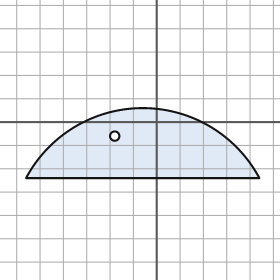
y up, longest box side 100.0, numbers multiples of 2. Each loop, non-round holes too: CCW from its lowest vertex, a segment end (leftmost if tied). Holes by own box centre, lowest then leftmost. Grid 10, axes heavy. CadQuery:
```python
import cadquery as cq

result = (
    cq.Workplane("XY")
    .moveTo(-56.0, -24.0)
    .lineTo(44.0, -24.0)
    .threePointArc((-6.0, 6.0), (-56.0, -24.0))
    .close()
    .moveTo(-18.0, -6.0)
    .circle(2.0)
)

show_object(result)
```